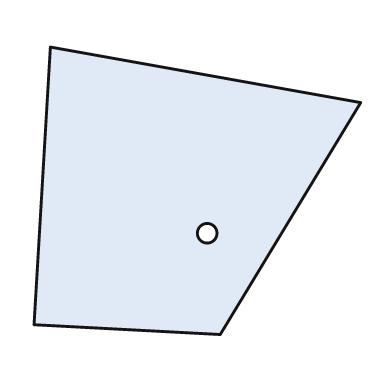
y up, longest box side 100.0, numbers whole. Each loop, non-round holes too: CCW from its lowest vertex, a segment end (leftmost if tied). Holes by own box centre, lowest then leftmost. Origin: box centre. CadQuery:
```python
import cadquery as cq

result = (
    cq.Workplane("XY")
    .moveTo(7.0, -44.0)
    .lineTo(50.0, 27.0)
    .lineTo(-45.0, 44.0)
    .lineTo(-50.0, -41.0)
    .close()
    .moveTo(3.0, -13.0)
    .circle(3.0)
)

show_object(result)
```